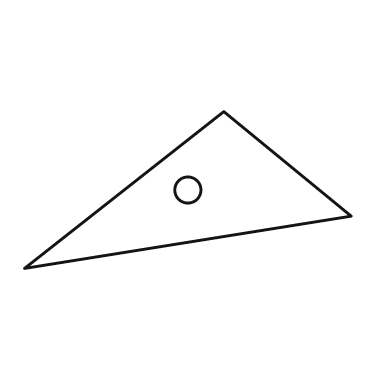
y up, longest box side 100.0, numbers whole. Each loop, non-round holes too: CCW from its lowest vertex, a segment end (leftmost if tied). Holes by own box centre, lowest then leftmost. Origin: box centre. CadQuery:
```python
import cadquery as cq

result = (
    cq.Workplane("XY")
    .moveTo(-50.0, -24.0)
    .lineTo(50.0, -8.0)
    .lineTo(11.0, 24.0)
    .close()
    .moveTo(0.0, 0.0)
    .circle(4.0)
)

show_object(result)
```